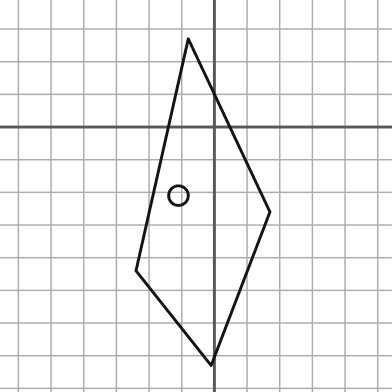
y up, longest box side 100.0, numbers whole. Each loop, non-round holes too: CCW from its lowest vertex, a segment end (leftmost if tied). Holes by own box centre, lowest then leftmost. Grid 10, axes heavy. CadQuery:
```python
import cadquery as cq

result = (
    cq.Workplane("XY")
    .moveTo(-1.0, -73.0)
    .lineTo(17.0, -26.0)
    .lineTo(-8.0, 27.0)
    .lineTo(-24.0, -44.0)
    .close()
    .moveTo(-11.0, -21.0)
    .circle(3.0)
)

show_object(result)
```